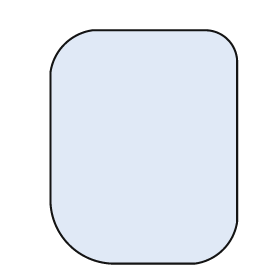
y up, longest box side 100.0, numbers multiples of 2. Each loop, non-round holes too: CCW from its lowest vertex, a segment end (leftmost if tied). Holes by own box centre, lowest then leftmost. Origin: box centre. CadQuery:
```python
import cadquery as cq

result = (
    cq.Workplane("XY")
    .moveTo(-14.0, -50.0)
    .lineTo(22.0, -50.0)
    .threePointArc((34.0, -44.0), (40.0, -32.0))
    .lineTo(40.0, 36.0)
    .threePointArc((36.0, 46.0), (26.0, 50.0))
    .lineTo(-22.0, 50.0)
    .threePointArc((-34.0, 44.0), (-40.0, 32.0))
    .lineTo(-40.0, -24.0)
    .threePointArc((-32.0, -42.0), (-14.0, -50.0))
    .close()
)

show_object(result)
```